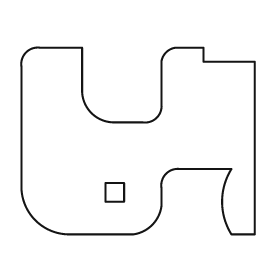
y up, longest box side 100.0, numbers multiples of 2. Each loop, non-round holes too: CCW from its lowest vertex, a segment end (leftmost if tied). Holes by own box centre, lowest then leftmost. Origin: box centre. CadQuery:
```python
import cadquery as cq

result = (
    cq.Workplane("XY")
    .moveTo(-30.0, -40.0)
    .lineTo(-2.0, -40.0)
    .threePointArc((6.0, -36.0), (10.0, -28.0))
    .lineTo(10.0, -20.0)
    .threePointArc((12.0, -14.0), (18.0, -12.0))
    .lineTo(40.0, -12.0)
    .threePointArc((36.0, -26.0), (40.0, -40.0))
    .lineTo(50.0, -40.0)
    .lineTo(50.0, 34.0)
    .lineTo(28.0, 34.0)
    .lineTo(28.0, 40.0)
    .lineTo(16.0, 40.0)
    .threePointArc((12.0, 38.0), (10.0, 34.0))
    .lineTo(10.0, 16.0)
    .threePointArc((8.0, 10.0), (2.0, 8.0))
    .lineTo(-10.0, 8.0)
    .threePointArc((-20.0, 12.0), (-24.0, 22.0))
    .lineTo(-24.0, 40.0)
    .lineTo(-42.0, 40.0)
    .threePointArc((-48.0, 38.0), (-50.0, 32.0))
    .lineTo(-50.0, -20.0)
    .threePointArc((-44.0, -34.0), (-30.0, -40.0))
    .close()
    .moveTo(-14.0, -26.0)
    .lineTo(-6.0, -26.0)
    .lineTo(-6.0, -18.0)
    .lineTo(-14.0, -18.0)
    .close()
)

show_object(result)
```